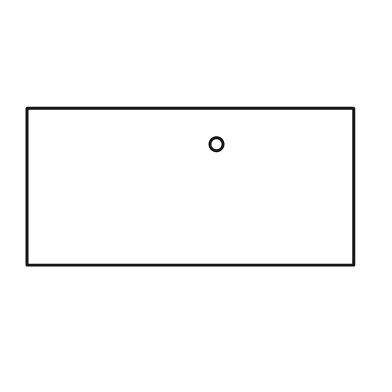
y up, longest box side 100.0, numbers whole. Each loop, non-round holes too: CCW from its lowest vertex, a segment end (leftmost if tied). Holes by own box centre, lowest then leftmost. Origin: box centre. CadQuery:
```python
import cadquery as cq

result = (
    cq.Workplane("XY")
    .moveTo(-50.0, -24.0)
    .lineTo(50.0, -24.0)
    .lineTo(50.0, 24.0)
    .lineTo(-50.0, 24.0)
    .close()
    .moveTo(8.0, 13.0)
    .circle(2.0)
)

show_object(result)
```